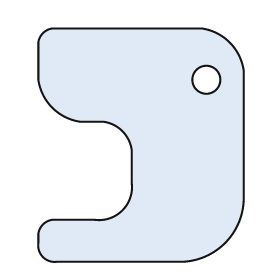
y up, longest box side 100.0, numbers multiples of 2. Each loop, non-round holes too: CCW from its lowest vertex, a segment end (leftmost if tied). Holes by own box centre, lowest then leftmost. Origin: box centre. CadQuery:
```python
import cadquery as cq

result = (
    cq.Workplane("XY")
    .moveTo(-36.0, -50.0)
    .lineTo(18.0, -50.0)
    .threePointArc((36.0, -42.0), (44.0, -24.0))
    .lineTo(44.0, 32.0)
    .threePointArc((38.0, 44.0), (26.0, 50.0))
    .lineTo(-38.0, 50.0)
    .threePointArc((-42.0, 48.0), (-44.0, 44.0))
    .lineTo(-44.0, 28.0)
    .threePointArc((-38.0, 16.0), (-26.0, 10.0))
    .lineTo(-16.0, 10.0)
    .threePointArc((-8.0, 6.0), (-4.0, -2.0))
    .lineTo(-4.0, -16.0)
    .threePointArc((-8.0, -28.0), (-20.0, -32.0))
    .lineTo(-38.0, -32.0)
    .threePointArc((-42.0, -34.0), (-44.0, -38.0))
    .lineTo(-44.0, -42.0)
    .threePointArc((-42.0, -48.0), (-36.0, -50.0))
    .close()
    .moveTo(28.0, 28.0)
    .circle(6.0)
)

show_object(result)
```